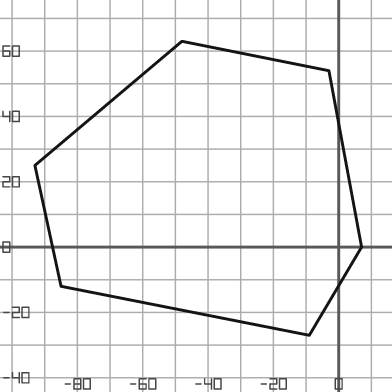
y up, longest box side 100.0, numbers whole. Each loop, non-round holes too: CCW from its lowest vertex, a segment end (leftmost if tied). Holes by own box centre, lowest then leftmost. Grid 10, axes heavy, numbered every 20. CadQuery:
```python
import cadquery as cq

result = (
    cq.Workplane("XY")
    .moveTo(-9.0, -27.0)
    .lineTo(7.0, 0.0)
    .lineTo(-3.0, 54.0)
    .lineTo(-48.0, 63.0)
    .lineTo(-93.0, 25.0)
    .lineTo(-85.0, -12.0)
    .close()
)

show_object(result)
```